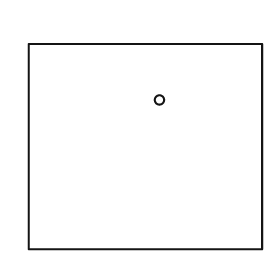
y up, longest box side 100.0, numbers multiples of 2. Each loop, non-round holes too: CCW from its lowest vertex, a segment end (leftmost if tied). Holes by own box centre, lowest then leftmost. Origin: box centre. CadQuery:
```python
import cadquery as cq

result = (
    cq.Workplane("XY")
    .moveTo(-50.0, -44.0)
    .lineTo(50.0, -44.0)
    .lineTo(50.0, 44.0)
    .lineTo(-50.0, 44.0)
    .close()
    .moveTo(6.0, 20.0)
    .circle(2.0)
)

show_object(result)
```